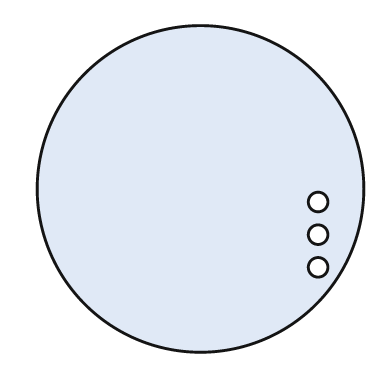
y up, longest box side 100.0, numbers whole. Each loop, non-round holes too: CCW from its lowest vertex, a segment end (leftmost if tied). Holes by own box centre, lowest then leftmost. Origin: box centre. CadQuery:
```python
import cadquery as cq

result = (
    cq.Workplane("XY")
    .moveTo(0.0, 0.0)
    .circle(50.0)
    .moveTo(36.0, -24.0)
    .circle(3.0)
    .moveTo(36.0, -14.0)
    .circle(3.0)
    .moveTo(36.0, -4.0)
    .circle(3.0)
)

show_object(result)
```